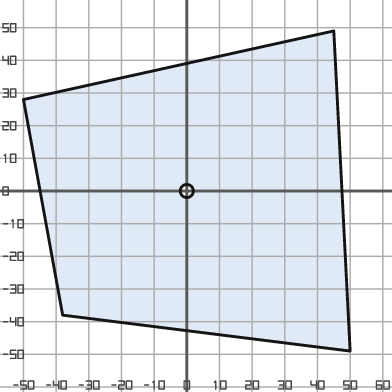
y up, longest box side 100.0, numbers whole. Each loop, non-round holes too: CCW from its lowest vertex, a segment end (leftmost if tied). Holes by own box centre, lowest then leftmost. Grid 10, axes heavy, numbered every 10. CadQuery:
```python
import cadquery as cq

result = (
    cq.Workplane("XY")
    .moveTo(50.0, -49.0)
    .lineTo(45.0, 49.0)
    .lineTo(-50.0, 28.0)
    .lineTo(-38.0, -38.0)
    .close()
    .moveTo(0.0, 0.0)
    .circle(2.0)
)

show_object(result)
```